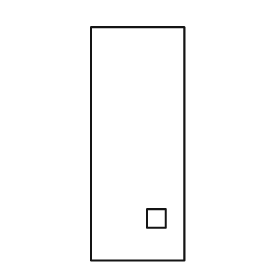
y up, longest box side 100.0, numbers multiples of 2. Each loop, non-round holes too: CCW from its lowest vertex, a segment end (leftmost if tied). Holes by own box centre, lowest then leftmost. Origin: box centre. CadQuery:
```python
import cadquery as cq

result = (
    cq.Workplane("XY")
    .moveTo(-20.0, -50.0)
    .lineTo(20.0, -50.0)
    .lineTo(20.0, 50.0)
    .lineTo(-20.0, 50.0)
    .close()
    .moveTo(4.0, -36.0)
    .lineTo(12.0, -36.0)
    .lineTo(12.0, -28.0)
    .lineTo(4.0, -28.0)
    .close()
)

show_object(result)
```